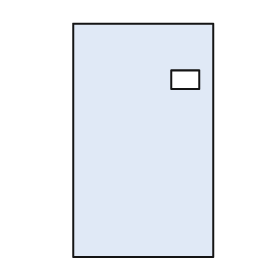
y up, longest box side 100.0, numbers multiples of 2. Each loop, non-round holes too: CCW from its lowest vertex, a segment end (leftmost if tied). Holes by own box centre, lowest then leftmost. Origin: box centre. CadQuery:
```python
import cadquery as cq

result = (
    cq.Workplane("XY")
    .moveTo(-30.0, -50.0)
    .lineTo(30.0, -50.0)
    .lineTo(30.0, 50.0)
    .lineTo(-30.0, 50.0)
    .close()
    .moveTo(12.0, 22.0)
    .lineTo(24.0, 22.0)
    .lineTo(24.0, 30.0)
    .lineTo(12.0, 30.0)
    .close()
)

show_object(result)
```